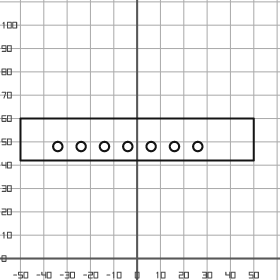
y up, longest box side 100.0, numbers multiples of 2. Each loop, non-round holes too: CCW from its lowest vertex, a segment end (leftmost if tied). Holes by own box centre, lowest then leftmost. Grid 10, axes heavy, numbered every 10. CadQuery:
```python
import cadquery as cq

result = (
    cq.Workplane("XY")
    .moveTo(-50.0, 42.0)
    .lineTo(50.0, 42.0)
    .lineTo(50.0, 60.0)
    .lineTo(-50.0, 60.0)
    .close()
    .moveTo(-34.0, 48.0)
    .circle(2.0)
    .moveTo(-24.0, 48.0)
    .circle(2.0)
    .moveTo(-14.0, 48.0)
    .circle(2.0)
    .moveTo(-4.0, 48.0)
    .circle(2.0)
    .moveTo(6.0, 48.0)
    .circle(2.0)
    .moveTo(16.0, 48.0)
    .circle(2.0)
    .moveTo(26.0, 48.0)
    .circle(2.0)
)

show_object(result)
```